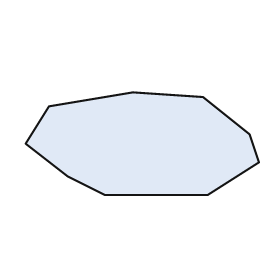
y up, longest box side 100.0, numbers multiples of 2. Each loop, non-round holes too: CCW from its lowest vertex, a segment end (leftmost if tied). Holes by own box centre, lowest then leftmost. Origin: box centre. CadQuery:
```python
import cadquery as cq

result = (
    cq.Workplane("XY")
    .moveTo(-16.0, -22.0)
    .lineTo(28.0, -22.0)
    .lineTo(50.0, -8.0)
    .lineTo(46.0, 4.0)
    .lineTo(26.0, 20.0)
    .lineTo(-4.0, 22.0)
    .lineTo(-40.0, 16.0)
    .lineTo(-50.0, 0.0)
    .lineTo(-32.0, -14.0)
    .close()
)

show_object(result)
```